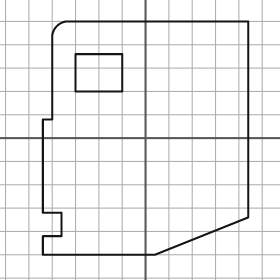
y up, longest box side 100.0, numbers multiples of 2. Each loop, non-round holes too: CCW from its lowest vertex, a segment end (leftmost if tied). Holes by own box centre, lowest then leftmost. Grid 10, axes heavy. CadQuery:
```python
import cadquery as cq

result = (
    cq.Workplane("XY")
    .moveTo(-44.0, -50.0)
    .lineTo(4.0, -50.0)
    .lineTo(44.0, -34.0)
    .lineTo(44.0, 50.0)
    .lineTo(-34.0, 50.0)
    .threePointArc((-38.0, 48.0), (-40.0, 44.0))
    .lineTo(-40.0, 8.0)
    .lineTo(-44.0, 8.0)
    .lineTo(-44.0, -32.0)
    .lineTo(-36.0, -32.0)
    .lineTo(-36.0, -42.0)
    .lineTo(-44.0, -42.0)
    .close()
    .moveTo(-30.0, 20.0)
    .lineTo(-10.0, 20.0)
    .lineTo(-10.0, 36.0)
    .lineTo(-30.0, 36.0)
    .close()
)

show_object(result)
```